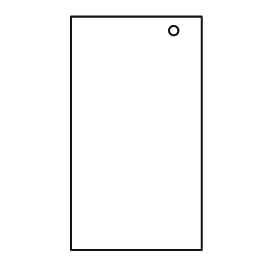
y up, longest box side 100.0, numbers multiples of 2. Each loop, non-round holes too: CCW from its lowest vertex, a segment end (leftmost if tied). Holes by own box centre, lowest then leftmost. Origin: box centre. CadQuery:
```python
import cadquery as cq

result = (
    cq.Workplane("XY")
    .moveTo(-28.0, -50.0)
    .lineTo(28.0, -50.0)
    .lineTo(28.0, 50.0)
    .lineTo(-28.0, 50.0)
    .close()
    .moveTo(16.0, 44.0)
    .circle(2.0)
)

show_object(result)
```